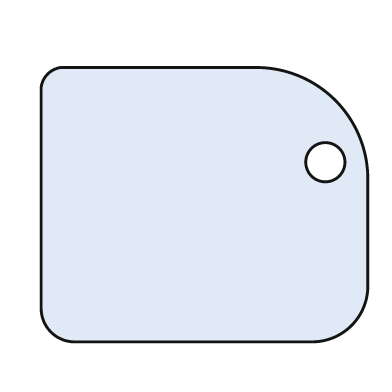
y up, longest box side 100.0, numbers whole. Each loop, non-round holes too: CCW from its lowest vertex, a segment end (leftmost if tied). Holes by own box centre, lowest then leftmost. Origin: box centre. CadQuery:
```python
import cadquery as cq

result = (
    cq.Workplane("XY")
    .moveTo(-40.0, -42.0)
    .lineTo(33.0, -42.0)
    .threePointArc((45.0, -37.0), (50.0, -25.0))
    .lineTo(50.0, 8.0)
    .threePointArc((40.0, 32.0), (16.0, 42.0))
    .lineTo(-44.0, 42.0)
    .threePointArc((-48.0, 40.0), (-50.0, 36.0))
    .lineTo(-50.0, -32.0)
    .threePointArc((-47.0, -39.0), (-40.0, -42.0))
    .close()
    .moveTo(37.0, 13.0)
    .circle(6.0)
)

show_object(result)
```